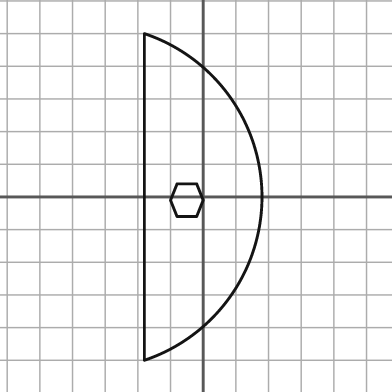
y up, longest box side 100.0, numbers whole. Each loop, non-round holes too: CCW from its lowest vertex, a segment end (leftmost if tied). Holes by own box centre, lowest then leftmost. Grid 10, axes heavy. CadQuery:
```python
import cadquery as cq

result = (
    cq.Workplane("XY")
    .moveTo(-18.0, -50.0)
    .threePointArc((18.0, 0.0), (-18.0, 50.0))
    .close()
    .moveTo(-8.0, -6.0)
    .lineTo(-2.0, -6.0)
    .lineTo(0.0, -1.0)
    .lineTo(-2.0, 4.0)
    .lineTo(-8.0, 4.0)
    .lineTo(-10.0, -1.0)
    .close()
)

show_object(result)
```